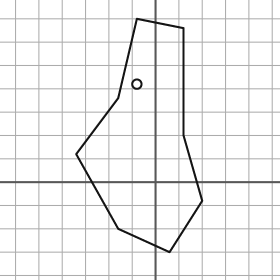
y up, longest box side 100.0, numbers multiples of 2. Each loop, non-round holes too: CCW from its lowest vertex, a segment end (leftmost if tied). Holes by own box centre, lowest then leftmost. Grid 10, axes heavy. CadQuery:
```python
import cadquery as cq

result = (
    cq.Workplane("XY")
    .moveTo(6.0, -30.0)
    .lineTo(20.0, -8.0)
    .lineTo(12.0, 20.0)
    .lineTo(12.0, 66.0)
    .lineTo(-8.0, 70.0)
    .lineTo(-16.0, 36.0)
    .lineTo(-34.0, 12.0)
    .lineTo(-16.0, -20.0)
    .close()
    .moveTo(-8.0, 42.0)
    .circle(2.0)
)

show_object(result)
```